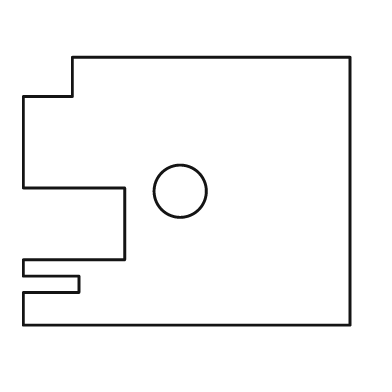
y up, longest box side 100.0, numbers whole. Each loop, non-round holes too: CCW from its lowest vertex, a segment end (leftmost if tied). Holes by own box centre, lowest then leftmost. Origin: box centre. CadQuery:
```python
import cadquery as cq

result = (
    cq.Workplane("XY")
    .moveTo(-50.0, -41.0)
    .lineTo(50.0, -41.0)
    .lineTo(50.0, 41.0)
    .lineTo(-35.0, 41.0)
    .lineTo(-35.0, 29.0)
    .lineTo(-50.0, 29.0)
    .lineTo(-50.0, 1.0)
    .lineTo(-19.0, 1.0)
    .lineTo(-19.0, -21.0)
    .lineTo(-50.0, -21.0)
    .lineTo(-50.0, -26.0)
    .lineTo(-33.0, -26.0)
    .lineTo(-33.0, -31.0)
    .lineTo(-50.0, -31.0)
    .close()
    .moveTo(-2.0, 0.0)
    .circle(8.0)
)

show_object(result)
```